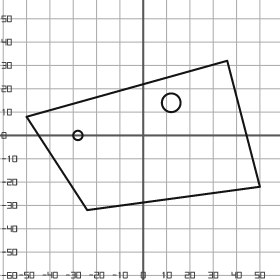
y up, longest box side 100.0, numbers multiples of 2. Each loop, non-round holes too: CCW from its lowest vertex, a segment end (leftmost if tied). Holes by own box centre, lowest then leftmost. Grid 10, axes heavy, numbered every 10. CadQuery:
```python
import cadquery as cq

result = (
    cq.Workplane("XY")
    .moveTo(-24.0, -32.0)
    .lineTo(50.0, -22.0)
    .lineTo(36.0, 32.0)
    .lineTo(-50.0, 8.0)
    .close()
    .moveTo(-28.0, 0.0)
    .circle(2.0)
    .moveTo(12.0, 14.0)
    .circle(4.0)
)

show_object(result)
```